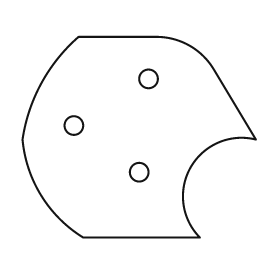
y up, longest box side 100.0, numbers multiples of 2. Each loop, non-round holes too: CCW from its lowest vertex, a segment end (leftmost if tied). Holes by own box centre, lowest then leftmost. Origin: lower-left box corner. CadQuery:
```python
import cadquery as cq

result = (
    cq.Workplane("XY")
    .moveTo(26.0, 0.0)
    .lineTo(76.0, 0.0)
    .threePointArc((72.0, 30.0), (100.0, 42.0))
    .lineTo(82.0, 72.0)
    .threePointArc((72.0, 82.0), (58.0, 86.0))
    .lineTo(24.0, 86.0)
    .threePointArc((8.0, 66.0), (0.0, 42.0))
    .threePointArc((8.0, 18.0), (26.0, 0.0))
    .close()
    .moveTo(50.0, 28.0)
    .circle(4.0)
    .moveTo(22.0, 48.0)
    .circle(4.0)
    .moveTo(54.0, 68.0)
    .circle(4.0)
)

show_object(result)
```